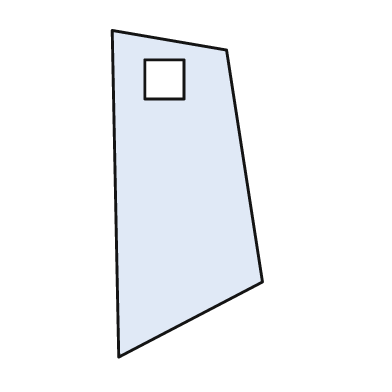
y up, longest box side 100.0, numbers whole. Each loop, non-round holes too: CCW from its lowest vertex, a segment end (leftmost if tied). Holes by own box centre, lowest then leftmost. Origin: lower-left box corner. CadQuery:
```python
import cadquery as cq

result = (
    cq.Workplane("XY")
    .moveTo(2.0, 0.0)
    .lineTo(46.0, 23.0)
    .lineTo(35.0, 94.0)
    .lineTo(0.0, 100.0)
    .close()
    .moveTo(10.0, 79.0)
    .lineTo(22.0, 79.0)
    .lineTo(22.0, 91.0)
    .lineTo(10.0, 91.0)
    .close()
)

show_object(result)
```